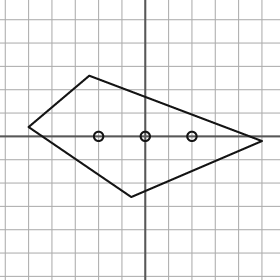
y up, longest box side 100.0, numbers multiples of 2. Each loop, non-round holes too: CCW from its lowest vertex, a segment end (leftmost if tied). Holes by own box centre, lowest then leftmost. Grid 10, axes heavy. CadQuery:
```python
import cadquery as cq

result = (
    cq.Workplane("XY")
    .moveTo(-6.0, -26.0)
    .lineTo(50.0, -2.0)
    .lineTo(-24.0, 26.0)
    .lineTo(-50.0, 4.0)
    .close()
    .moveTo(-20.0, 0.0)
    .circle(2.0)
    .moveTo(0.0, 0.0)
    .circle(2.0)
    .moveTo(20.0, 0.0)
    .circle(2.0)
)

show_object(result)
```